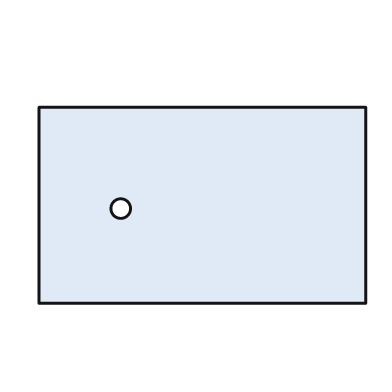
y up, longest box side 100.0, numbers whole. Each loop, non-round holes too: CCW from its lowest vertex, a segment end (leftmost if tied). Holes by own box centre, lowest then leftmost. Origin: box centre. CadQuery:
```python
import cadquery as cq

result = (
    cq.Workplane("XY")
    .moveTo(-50.0, -30.0)
    .lineTo(50.0, -30.0)
    .lineTo(50.0, 30.0)
    .lineTo(-50.0, 30.0)
    .close()
    .moveTo(-25.0, -1.0)
    .circle(3.0)
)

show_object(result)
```